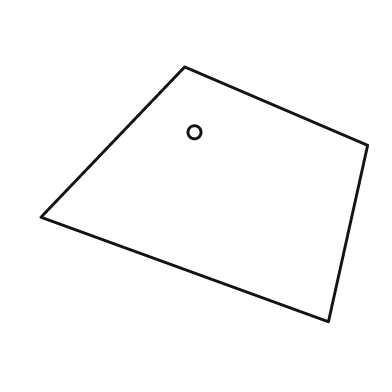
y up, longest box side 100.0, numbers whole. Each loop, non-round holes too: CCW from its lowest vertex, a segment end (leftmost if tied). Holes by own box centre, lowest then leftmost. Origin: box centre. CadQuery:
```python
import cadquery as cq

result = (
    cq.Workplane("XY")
    .moveTo(38.0, -39.0)
    .lineTo(50.0, 15.0)
    .lineTo(-6.0, 39.0)
    .lineTo(-50.0, -7.0)
    .close()
    .moveTo(-3.0, 19.0)
    .circle(2.0)
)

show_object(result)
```